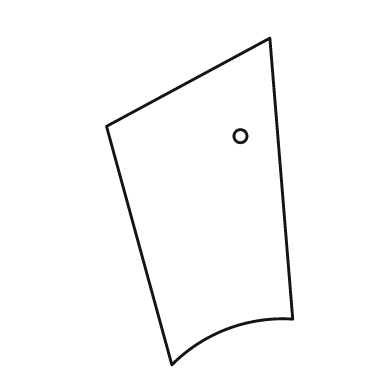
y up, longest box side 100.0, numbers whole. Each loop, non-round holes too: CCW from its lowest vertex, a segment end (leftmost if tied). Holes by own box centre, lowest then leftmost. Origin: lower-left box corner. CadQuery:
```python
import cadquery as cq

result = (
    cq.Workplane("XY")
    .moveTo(20.0, 0.0)
    .threePointArc((37.0, 11.0), (57.0, 14.0))
    .lineTo(50.0, 100.0)
    .lineTo(0.0, 73.0)
    .close()
    .moveTo(41.0, 70.0)
    .circle(2.0)
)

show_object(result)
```